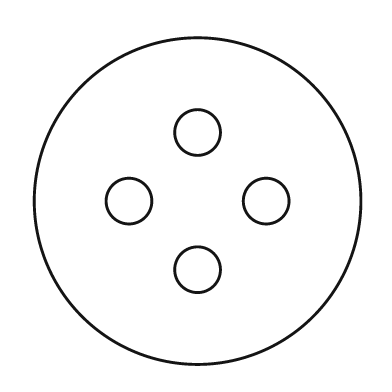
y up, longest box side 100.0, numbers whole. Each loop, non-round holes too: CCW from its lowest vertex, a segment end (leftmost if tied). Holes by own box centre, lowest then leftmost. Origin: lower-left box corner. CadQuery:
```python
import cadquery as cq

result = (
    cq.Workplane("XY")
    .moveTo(50.0, 50.0)
    .circle(50.0)
    .moveTo(50.0, 29.0)
    .circle(7.0)
    .moveTo(29.0, 50.0)
    .circle(7.0)
    .moveTo(71.0, 50.0)
    .circle(7.0)
    .moveTo(50.0, 71.0)
    .circle(7.0)
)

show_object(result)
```